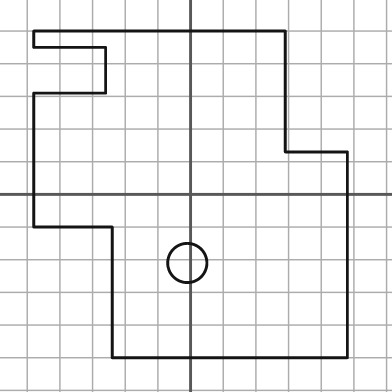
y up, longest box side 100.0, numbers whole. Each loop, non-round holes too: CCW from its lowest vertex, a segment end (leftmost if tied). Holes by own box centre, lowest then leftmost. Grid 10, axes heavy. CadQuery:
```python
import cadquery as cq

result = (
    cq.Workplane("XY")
    .moveTo(-24.0, -50.0)
    .lineTo(48.0, -50.0)
    .lineTo(48.0, 13.0)
    .lineTo(29.0, 13.0)
    .lineTo(29.0, 50.0)
    .lineTo(-48.0, 50.0)
    .lineTo(-48.0, 45.0)
    .lineTo(-26.0, 45.0)
    .lineTo(-26.0, 31.0)
    .lineTo(-48.0, 31.0)
    .lineTo(-48.0, -10.0)
    .lineTo(-24.0, -10.0)
    .close()
    .moveTo(-1.0, -21.0)
    .circle(6.0)
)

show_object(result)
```